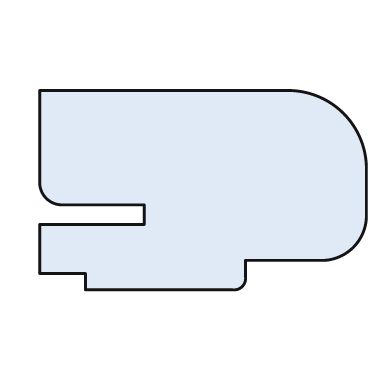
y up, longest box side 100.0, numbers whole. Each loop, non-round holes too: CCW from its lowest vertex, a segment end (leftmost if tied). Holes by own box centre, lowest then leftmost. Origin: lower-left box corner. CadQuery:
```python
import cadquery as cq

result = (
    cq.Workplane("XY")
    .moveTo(14.0, 0.0)
    .lineTo(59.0, 0.0)
    .threePointArc((62.0, 1.0), (63.0, 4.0))
    .lineTo(63.0, 9.0)
    .lineTo(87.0, 9.0)
    .threePointArc((96.0, 13.0), (100.0, 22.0))
    .lineTo(100.0, 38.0)
    .threePointArc((93.0, 54.0), (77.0, 61.0))
    .lineTo(0.0, 61.0)
    .lineTo(0.0, 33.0)
    .threePointArc((2.0, 28.0), (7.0, 26.0))
    .lineTo(32.0, 26.0)
    .lineTo(32.0, 20.0)
    .lineTo(0.0, 20.0)
    .lineTo(0.0, 5.0)
    .lineTo(14.0, 5.0)
    .close()
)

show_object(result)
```